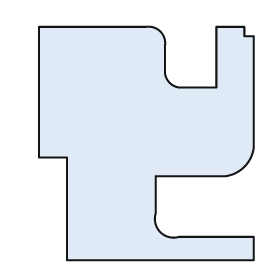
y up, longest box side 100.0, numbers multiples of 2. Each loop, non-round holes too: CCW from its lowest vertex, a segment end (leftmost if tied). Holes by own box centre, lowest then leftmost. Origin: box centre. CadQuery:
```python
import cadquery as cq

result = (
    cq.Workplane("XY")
    .moveTo(-34.0, -50.0)
    .lineTo(46.0, -50.0)
    .lineTo(46.0, -40.0)
    .lineTo(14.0, -40.0)
    .threePointArc((6.0, -38.0), (4.0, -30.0))
    .lineTo(4.0, -14.0)
    .lineTo(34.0, -14.0)
    .threePointArc((42.0, -10.0), (46.0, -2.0))
    .lineTo(46.0, 46.0)
    .lineTo(42.0, 46.0)
    .lineTo(42.0, 50.0)
    .lineTo(30.0, 50.0)
    .lineTo(30.0, 24.0)
    .lineTo(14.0, 24.0)
    .threePointArc((10.0, 26.0), (8.0, 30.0))
    .lineTo(8.0, 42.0)
    .threePointArc((6.0, 48.0), (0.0, 50.0))
    .lineTo(-46.0, 50.0)
    .lineTo(-46.0, -6.0)
    .lineTo(-34.0, -6.0)
    .close()
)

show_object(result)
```